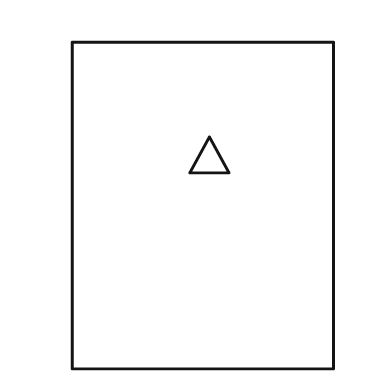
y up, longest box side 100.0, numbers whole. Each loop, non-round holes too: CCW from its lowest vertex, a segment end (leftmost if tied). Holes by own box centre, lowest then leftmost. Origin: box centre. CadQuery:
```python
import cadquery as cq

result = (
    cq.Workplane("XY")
    .moveTo(-40.0, -50.0)
    .lineTo(40.0, -50.0)
    .lineTo(40.0, 50.0)
    .lineTo(-40.0, 50.0)
    .close()
    .moveTo(-4.0, 10.0)
    .lineTo(8.0, 10.0)
    .lineTo(2.0, 21.0)
    .close()
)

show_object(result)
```